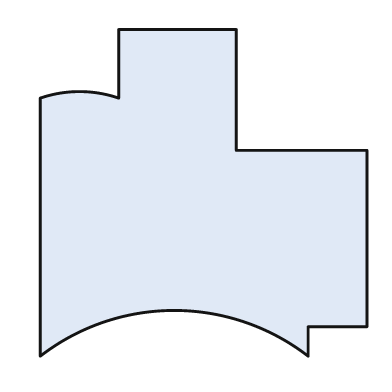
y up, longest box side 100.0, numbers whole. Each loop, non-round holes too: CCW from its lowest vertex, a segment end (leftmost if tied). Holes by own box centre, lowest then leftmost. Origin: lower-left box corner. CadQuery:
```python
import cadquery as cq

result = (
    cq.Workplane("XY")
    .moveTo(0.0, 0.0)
    .threePointArc((41.0, 14.0), (82.0, 0.0))
    .lineTo(82.0, 9.0)
    .lineTo(100.0, 9.0)
    .lineTo(100.0, 63.0)
    .lineTo(60.0, 63.0)
    .lineTo(60.0, 100.0)
    .lineTo(24.0, 100.0)
    .lineTo(24.0, 79.0)
    .threePointArc((12.0, 81.0), (0.0, 79.0))
    .close()
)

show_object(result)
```